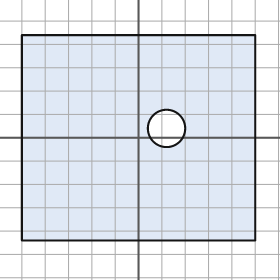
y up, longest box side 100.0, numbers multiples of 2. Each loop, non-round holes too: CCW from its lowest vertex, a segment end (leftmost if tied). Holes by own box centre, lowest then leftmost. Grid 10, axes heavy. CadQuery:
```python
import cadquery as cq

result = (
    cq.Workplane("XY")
    .moveTo(-50.0, -44.0)
    .lineTo(50.0, -44.0)
    .lineTo(50.0, 44.0)
    .lineTo(-50.0, 44.0)
    .close()
    .moveTo(12.0, 4.0)
    .circle(8.0)
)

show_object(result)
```